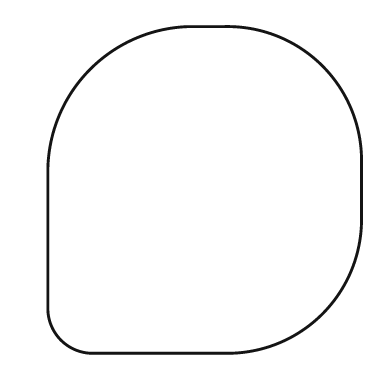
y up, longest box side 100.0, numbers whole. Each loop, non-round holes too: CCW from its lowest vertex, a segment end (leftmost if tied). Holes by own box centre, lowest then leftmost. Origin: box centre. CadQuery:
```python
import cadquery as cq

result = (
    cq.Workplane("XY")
    .moveTo(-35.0, -50.0)
    .lineTo(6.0, -50.0)
    .threePointArc((36.0, -38.0), (48.0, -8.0))
    .lineTo(48.0, 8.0)
    .threePointArc((36.0, 38.0), (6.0, 50.0))
    .lineTo(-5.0, 50.0)
    .threePointArc((-35.0, 37.0), (-48.0, 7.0))
    .lineTo(-48.0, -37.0)
    .threePointArc((-44.0, -46.0), (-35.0, -50.0))
    .close()
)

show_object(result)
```